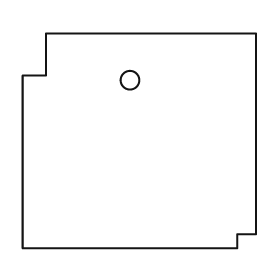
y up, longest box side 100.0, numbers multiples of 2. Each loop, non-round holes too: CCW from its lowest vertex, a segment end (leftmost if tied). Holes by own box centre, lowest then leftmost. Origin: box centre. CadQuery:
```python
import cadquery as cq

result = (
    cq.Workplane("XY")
    .moveTo(-50.0, -46.0)
    .lineTo(42.0, -46.0)
    .lineTo(42.0, -40.0)
    .lineTo(50.0, -40.0)
    .lineTo(50.0, 46.0)
    .lineTo(-40.0, 46.0)
    .lineTo(-40.0, 28.0)
    .lineTo(-50.0, 28.0)
    .close()
    .moveTo(-4.0, 26.0)
    .circle(4.0)
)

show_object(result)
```